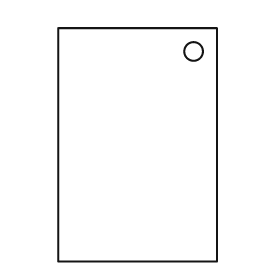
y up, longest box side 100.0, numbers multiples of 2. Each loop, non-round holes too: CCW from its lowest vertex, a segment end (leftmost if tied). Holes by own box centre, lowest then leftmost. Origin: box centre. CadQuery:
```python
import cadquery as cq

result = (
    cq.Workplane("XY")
    .moveTo(-34.0, -50.0)
    .lineTo(34.0, -50.0)
    .lineTo(34.0, 50.0)
    .lineTo(-34.0, 50.0)
    .close()
    .moveTo(24.0, 40.0)
    .circle(4.0)
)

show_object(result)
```